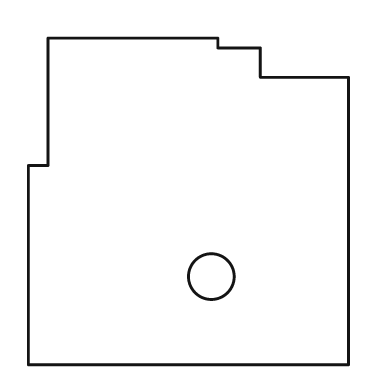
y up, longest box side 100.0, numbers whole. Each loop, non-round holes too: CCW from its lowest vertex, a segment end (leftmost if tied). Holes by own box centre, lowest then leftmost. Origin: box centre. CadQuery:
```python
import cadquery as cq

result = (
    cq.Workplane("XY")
    .moveTo(-49.0, -50.0)
    .lineTo(49.0, -50.0)
    .lineTo(49.0, 38.0)
    .lineTo(22.0, 38.0)
    .lineTo(22.0, 47.0)
    .lineTo(9.0, 47.0)
    .lineTo(9.0, 50.0)
    .lineTo(-43.0, 50.0)
    .lineTo(-43.0, 11.0)
    .lineTo(-49.0, 11.0)
    .close()
    .moveTo(7.0, -23.0)
    .circle(7.0)
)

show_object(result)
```